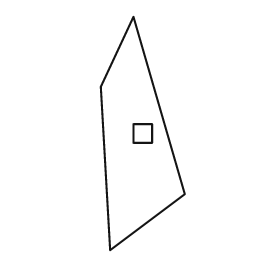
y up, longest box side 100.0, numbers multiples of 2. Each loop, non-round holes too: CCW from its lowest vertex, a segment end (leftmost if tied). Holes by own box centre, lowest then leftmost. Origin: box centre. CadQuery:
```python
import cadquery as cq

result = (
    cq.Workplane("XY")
    .moveTo(-14.0, -50.0)
    .lineTo(18.0, -26.0)
    .lineTo(-4.0, 50.0)
    .lineTo(-18.0, 20.0)
    .close()
    .moveTo(-4.0, -4.0)
    .lineTo(4.0, -4.0)
    .lineTo(4.0, 4.0)
    .lineTo(-4.0, 4.0)
    .close()
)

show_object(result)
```